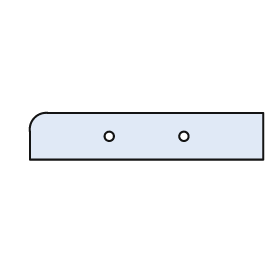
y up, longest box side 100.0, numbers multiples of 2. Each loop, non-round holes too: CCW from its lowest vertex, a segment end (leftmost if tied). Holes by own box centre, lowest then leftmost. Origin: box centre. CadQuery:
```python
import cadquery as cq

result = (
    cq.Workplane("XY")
    .moveTo(-50.0, -10.0)
    .lineTo(50.0, -10.0)
    .lineTo(50.0, 10.0)
    .lineTo(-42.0, 10.0)
    .threePointArc((-48.0, 8.0), (-50.0, 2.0))
    .close()
    .moveTo(-16.0, 0.0)
    .circle(2.0)
    .moveTo(16.0, 0.0)
    .circle(2.0)
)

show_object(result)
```